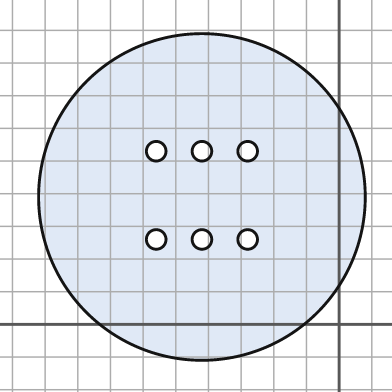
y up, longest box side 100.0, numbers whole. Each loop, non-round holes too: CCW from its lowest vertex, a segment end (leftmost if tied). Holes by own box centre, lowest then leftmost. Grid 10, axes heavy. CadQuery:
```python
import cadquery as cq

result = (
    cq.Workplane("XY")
    .moveTo(-42.0, 39.0)
    .circle(50.0)
    .moveTo(-56.0, 26.0)
    .circle(3.0)
    .moveTo(-42.0, 26.0)
    .circle(3.0)
    .moveTo(-28.0, 26.0)
    .circle(3.0)
    .moveTo(-56.0, 53.0)
    .circle(3.0)
    .moveTo(-42.0, 53.0)
    .circle(3.0)
    .moveTo(-28.0, 53.0)
    .circle(3.0)
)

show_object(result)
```